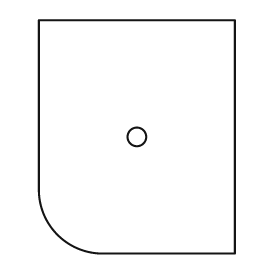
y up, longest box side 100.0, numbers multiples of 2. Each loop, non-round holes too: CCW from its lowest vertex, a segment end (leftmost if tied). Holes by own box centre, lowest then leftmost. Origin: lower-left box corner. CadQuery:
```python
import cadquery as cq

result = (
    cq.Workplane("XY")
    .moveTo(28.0, 0.0)
    .lineTo(84.0, 0.0)
    .lineTo(84.0, 100.0)
    .lineTo(0.0, 100.0)
    .lineTo(0.0, 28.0)
    .threePointArc((8.0, 8.0), (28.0, 0.0))
    .close()
    .moveTo(42.0, 50.0)
    .circle(4.0)
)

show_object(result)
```